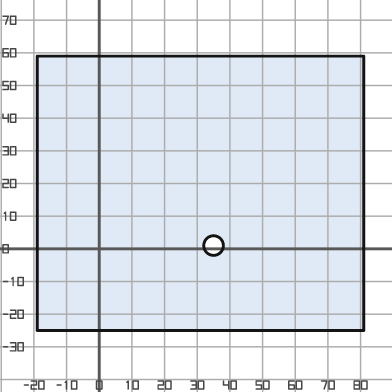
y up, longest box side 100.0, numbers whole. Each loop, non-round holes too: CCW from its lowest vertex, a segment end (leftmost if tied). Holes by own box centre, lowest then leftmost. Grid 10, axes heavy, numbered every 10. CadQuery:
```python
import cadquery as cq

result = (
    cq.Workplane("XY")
    .moveTo(-19.0, -25.0)
    .lineTo(81.0, -25.0)
    .lineTo(81.0, 59.0)
    .lineTo(-19.0, 59.0)
    .close()
    .moveTo(35.0, 1.0)
    .circle(3.0)
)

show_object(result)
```